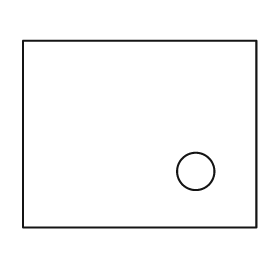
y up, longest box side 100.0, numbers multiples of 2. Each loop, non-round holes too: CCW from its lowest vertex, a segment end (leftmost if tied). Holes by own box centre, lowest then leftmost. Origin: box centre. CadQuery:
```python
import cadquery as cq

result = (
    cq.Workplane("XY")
    .moveTo(-50.0, -40.0)
    .lineTo(50.0, -40.0)
    .lineTo(50.0, 40.0)
    .lineTo(-50.0, 40.0)
    .close()
    .moveTo(24.0, -16.0)
    .circle(8.0)
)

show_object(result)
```